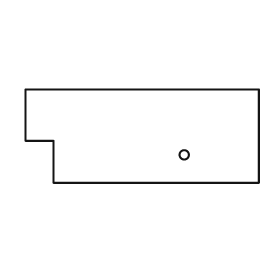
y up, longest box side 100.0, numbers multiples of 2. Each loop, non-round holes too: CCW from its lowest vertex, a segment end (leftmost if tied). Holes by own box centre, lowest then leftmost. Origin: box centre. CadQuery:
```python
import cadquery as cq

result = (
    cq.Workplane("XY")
    .moveTo(-38.0, -20.0)
    .lineTo(50.0, -20.0)
    .lineTo(50.0, 20.0)
    .lineTo(-50.0, 20.0)
    .lineTo(-50.0, -2.0)
    .lineTo(-38.0, -2.0)
    .close()
    .moveTo(18.0, -8.0)
    .circle(2.0)
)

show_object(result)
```